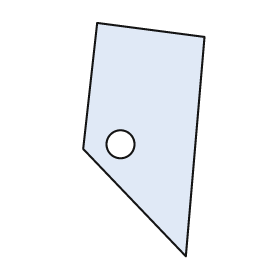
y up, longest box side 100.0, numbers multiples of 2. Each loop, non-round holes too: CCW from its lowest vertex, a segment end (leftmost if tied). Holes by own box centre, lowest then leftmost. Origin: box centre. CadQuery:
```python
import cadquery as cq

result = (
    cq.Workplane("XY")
    .moveTo(18.0, -50.0)
    .lineTo(26.0, 44.0)
    .lineTo(-20.0, 50.0)
    .lineTo(-26.0, -4.0)
    .close()
    .moveTo(-10.0, -2.0)
    .circle(6.0)
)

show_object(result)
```